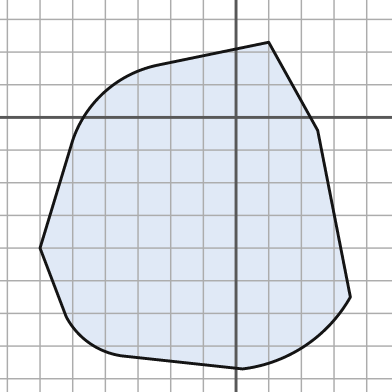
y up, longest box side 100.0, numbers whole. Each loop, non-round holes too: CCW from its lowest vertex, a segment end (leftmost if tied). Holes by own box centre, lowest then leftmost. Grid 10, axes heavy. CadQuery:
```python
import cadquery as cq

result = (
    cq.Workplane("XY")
    .moveTo(2.0, -77.0)
    .threePointArc((21.0, -70.0), (35.0, -55.0))
    .lineTo(25.0, -4.0)
    .lineTo(10.0, 23.0)
    .lineTo(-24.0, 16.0)
    .threePointArc((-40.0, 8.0), (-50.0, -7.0))
    .lineTo(-60.0, -40.0)
    .lineTo(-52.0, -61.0)
    .threePointArc((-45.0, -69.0), (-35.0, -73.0))
    .close()
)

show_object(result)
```